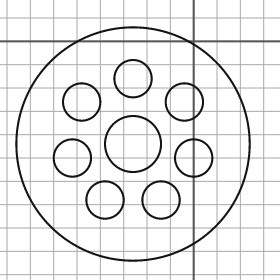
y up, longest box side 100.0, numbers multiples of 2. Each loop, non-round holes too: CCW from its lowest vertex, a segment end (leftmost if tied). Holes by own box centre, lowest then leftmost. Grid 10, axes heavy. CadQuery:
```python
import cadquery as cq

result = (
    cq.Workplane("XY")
    .moveTo(-26.0, -44.0)
    .circle(50.0)
    .moveTo(-38.0, -68.0)
    .circle(8.0)
    .moveTo(-14.0, -68.0)
    .circle(8.0)
    .moveTo(-52.0, -50.0)
    .circle(8.0)
    .moveTo(0.0, -50.0)
    .circle(8.0)
    .moveTo(-26.0, -44.0)
    .circle(12.0)
    .moveTo(-48.0, -26.0)
    .circle(8.0)
    .moveTo(-4.0, -26.0)
    .circle(8.0)
    .moveTo(-26.0, -16.0)
    .circle(8.0)
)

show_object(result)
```